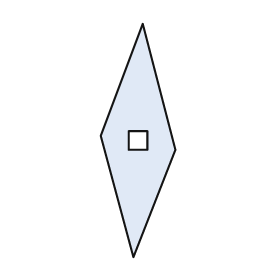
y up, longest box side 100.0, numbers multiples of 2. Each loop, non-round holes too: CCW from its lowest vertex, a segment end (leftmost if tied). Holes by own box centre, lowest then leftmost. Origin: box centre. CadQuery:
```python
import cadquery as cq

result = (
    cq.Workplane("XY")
    .moveTo(-2.0, -50.0)
    .lineTo(16.0, -4.0)
    .lineTo(2.0, 50.0)
    .lineTo(-16.0, 2.0)
    .close()
    .moveTo(-4.0, -4.0)
    .lineTo(4.0, -4.0)
    .lineTo(4.0, 4.0)
    .lineTo(-4.0, 4.0)
    .close()
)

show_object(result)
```